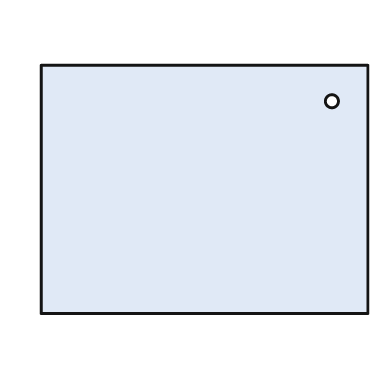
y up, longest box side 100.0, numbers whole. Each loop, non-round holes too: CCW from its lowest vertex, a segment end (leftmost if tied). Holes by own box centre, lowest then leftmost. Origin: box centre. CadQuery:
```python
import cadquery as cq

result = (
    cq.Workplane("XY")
    .moveTo(-50.0, -38.0)
    .lineTo(50.0, -38.0)
    .lineTo(50.0, 38.0)
    .lineTo(-50.0, 38.0)
    .close()
    .moveTo(39.0, 27.0)
    .circle(2.0)
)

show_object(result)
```